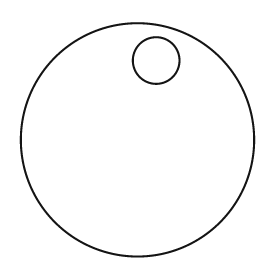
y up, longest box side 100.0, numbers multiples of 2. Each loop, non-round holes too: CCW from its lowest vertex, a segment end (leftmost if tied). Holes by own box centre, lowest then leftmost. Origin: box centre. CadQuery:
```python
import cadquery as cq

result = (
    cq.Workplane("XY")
    .moveTo(0.0, 0.0)
    .circle(50.0)
    .moveTo(8.0, 34.0)
    .circle(10.0)
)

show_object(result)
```